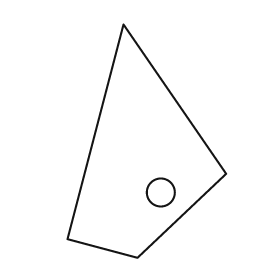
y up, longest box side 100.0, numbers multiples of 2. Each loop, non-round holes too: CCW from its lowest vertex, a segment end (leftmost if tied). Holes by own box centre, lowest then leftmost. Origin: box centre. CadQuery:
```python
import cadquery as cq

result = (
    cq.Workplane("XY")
    .moveTo(-4.0, -50.0)
    .lineTo(34.0, -14.0)
    .lineTo(-10.0, 50.0)
    .lineTo(-34.0, -42.0)
    .close()
    .moveTo(6.0, -22.0)
    .circle(6.0)
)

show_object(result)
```